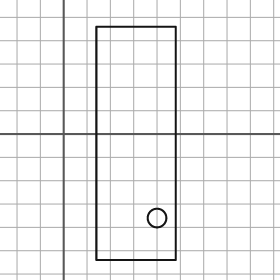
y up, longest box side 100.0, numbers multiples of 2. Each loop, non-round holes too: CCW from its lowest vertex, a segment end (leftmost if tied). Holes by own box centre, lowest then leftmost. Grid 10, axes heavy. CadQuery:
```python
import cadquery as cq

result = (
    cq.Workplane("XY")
    .moveTo(14.0, -54.0)
    .lineTo(48.0, -54.0)
    .lineTo(48.0, 46.0)
    .lineTo(14.0, 46.0)
    .close()
    .moveTo(40.0, -36.0)
    .circle(4.0)
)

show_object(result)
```